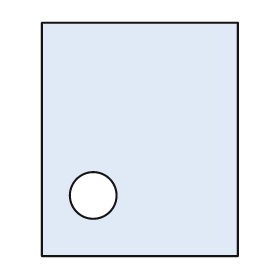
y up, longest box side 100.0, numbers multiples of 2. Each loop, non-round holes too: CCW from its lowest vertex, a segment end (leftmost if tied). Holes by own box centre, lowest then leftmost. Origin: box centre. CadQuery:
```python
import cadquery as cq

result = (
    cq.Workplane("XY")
    .moveTo(-42.0, -50.0)
    .lineTo(42.0, -50.0)
    .lineTo(42.0, 50.0)
    .lineTo(-42.0, 50.0)
    .close()
    .moveTo(-20.0, -24.0)
    .circle(10.0)
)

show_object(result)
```